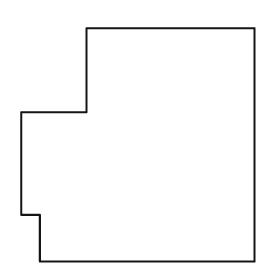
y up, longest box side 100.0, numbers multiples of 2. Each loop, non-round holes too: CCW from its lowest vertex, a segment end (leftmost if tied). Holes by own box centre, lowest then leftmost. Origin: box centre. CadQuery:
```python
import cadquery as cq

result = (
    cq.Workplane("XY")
    .moveTo(-42.0, -50.0)
    .lineTo(50.0, -50.0)
    .lineTo(50.0, 50.0)
    .lineTo(-22.0, 50.0)
    .lineTo(-22.0, 14.0)
    .lineTo(-50.0, 14.0)
    .lineTo(-50.0, -30.0)
    .lineTo(-42.0, -30.0)
    .close()
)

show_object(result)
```